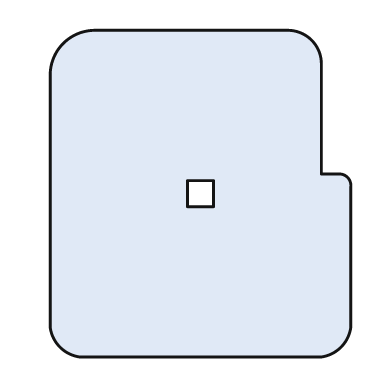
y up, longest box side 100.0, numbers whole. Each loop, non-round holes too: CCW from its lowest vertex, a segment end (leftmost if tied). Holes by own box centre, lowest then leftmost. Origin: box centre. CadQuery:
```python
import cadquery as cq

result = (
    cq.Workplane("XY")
    .moveTo(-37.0, -50.0)
    .lineTo(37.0, -50.0)
    .threePointArc((43.0, -47.0), (46.0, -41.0))
    .lineTo(46.0, 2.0)
    .threePointArc((45.0, 5.0), (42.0, 6.0))
    .lineTo(37.0, 6.0)
    .lineTo(37.0, 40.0)
    .threePointArc((34.0, 47.0), (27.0, 50.0))
    .lineTo(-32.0, 50.0)
    .threePointArc((-42.0, 46.0), (-46.0, 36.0))
    .lineTo(-46.0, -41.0)
    .threePointArc((-43.0, -47.0), (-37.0, -50.0))
    .close()
    .moveTo(-4.0, -4.0)
    .lineTo(4.0, -4.0)
    .lineTo(4.0, 4.0)
    .lineTo(-4.0, 4.0)
    .close()
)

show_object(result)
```